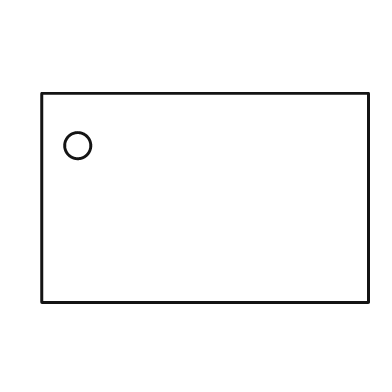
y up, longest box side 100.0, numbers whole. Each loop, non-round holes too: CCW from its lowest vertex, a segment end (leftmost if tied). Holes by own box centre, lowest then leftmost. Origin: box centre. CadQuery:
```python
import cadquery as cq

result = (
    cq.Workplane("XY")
    .moveTo(-50.0, -32.0)
    .lineTo(50.0, -32.0)
    .lineTo(50.0, 32.0)
    .lineTo(-50.0, 32.0)
    .close()
    .moveTo(-39.0, 16.0)
    .circle(4.0)
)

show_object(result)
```